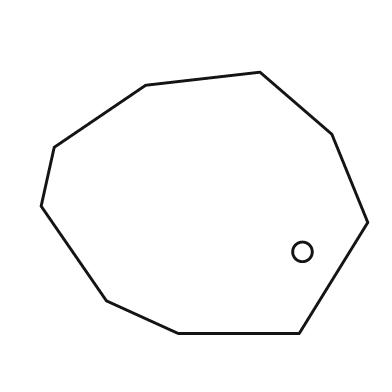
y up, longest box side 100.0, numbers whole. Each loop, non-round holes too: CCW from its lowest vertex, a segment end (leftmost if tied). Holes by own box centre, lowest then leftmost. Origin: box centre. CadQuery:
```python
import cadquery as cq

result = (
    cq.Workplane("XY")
    .moveTo(-8.0, -40.0)
    .lineTo(29.0, -40.0)
    .lineTo(50.0, -6.0)
    .lineTo(39.0, 21.0)
    .lineTo(17.0, 40.0)
    .lineTo(-18.0, 36.0)
    .lineTo(-46.0, 17.0)
    .lineTo(-50.0, -1.0)
    .lineTo(-30.0, -30.0)
    .close()
    .moveTo(30.0, -15.0)
    .circle(3.0)
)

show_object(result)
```